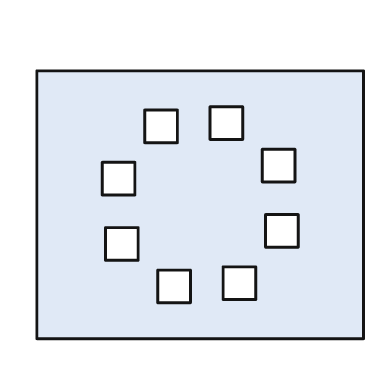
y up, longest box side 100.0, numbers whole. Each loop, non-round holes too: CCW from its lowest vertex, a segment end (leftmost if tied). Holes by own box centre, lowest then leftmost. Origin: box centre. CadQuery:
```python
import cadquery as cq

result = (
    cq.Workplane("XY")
    .moveTo(-50.0, -41.0)
    .lineTo(50.0, -41.0)
    .lineTo(50.0, 41.0)
    .lineTo(-50.0, 41.0)
    .close()
    .moveTo(-13.0, -30.0)
    .lineTo(-3.0, -30.0)
    .lineTo(-3.0, -20.0)
    .lineTo(-13.0, -20.0)
    .close()
    .moveTo(7.0, -29.0)
    .lineTo(17.0, -29.0)
    .lineTo(17.0, -19.0)
    .lineTo(7.0, -19.0)
    .close()
    .moveTo(-29.0, -17.0)
    .lineTo(-19.0, -17.0)
    .lineTo(-19.0, -7.0)
    .lineTo(-29.0, -7.0)
    .close()
    .moveTo(20.0, -13.0)
    .lineTo(30.0, -13.0)
    .lineTo(30.0, -3.0)
    .lineTo(20.0, -3.0)
    .close()
    .moveTo(-30.0, 3.0)
    .lineTo(-20.0, 3.0)
    .lineTo(-20.0, 13.0)
    .lineTo(-30.0, 13.0)
    .close()
    .moveTo(19.0, 7.0)
    .lineTo(29.0, 7.0)
    .lineTo(29.0, 17.0)
    .lineTo(19.0, 17.0)
    .close()
    .moveTo(-17.0, 19.0)
    .lineTo(-7.0, 19.0)
    .lineTo(-7.0, 29.0)
    .lineTo(-17.0, 29.0)
    .close()
    .moveTo(3.0, 20.0)
    .lineTo(13.0, 20.0)
    .lineTo(13.0, 30.0)
    .lineTo(3.0, 30.0)
    .close()
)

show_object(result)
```